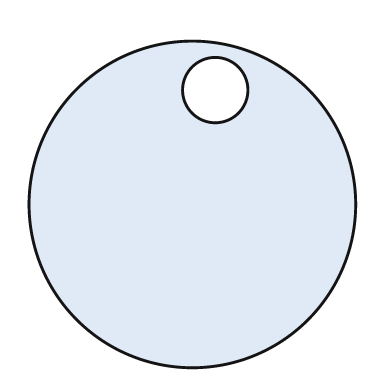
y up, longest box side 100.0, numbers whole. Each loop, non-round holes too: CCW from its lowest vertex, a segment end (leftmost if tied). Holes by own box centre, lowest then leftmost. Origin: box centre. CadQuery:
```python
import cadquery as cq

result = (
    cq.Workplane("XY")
    .moveTo(0.0, 0.0)
    .circle(50.0)
    .moveTo(7.0, 35.0)
    .circle(10.0)
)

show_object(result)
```